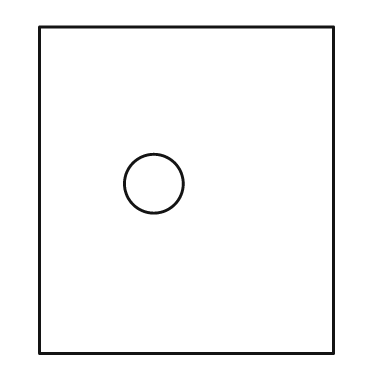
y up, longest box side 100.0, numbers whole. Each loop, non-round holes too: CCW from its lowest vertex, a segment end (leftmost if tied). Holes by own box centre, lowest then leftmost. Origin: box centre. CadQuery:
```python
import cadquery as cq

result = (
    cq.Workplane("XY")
    .moveTo(-45.0, -50.0)
    .lineTo(45.0, -50.0)
    .lineTo(45.0, 50.0)
    .lineTo(-45.0, 50.0)
    .close()
    .moveTo(-10.0, 2.0)
    .circle(9.0)
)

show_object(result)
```